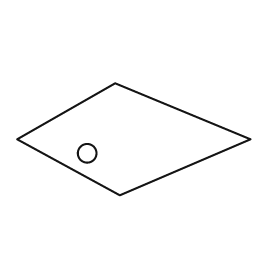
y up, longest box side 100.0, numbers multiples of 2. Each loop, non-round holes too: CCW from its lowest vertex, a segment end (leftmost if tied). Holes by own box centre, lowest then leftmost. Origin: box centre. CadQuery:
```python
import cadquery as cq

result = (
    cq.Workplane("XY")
    .moveTo(-6.0, -24.0)
    .lineTo(50.0, 0.0)
    .lineTo(-8.0, 24.0)
    .lineTo(-50.0, 0.0)
    .close()
    .moveTo(-20.0, -6.0)
    .circle(4.0)
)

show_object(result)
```